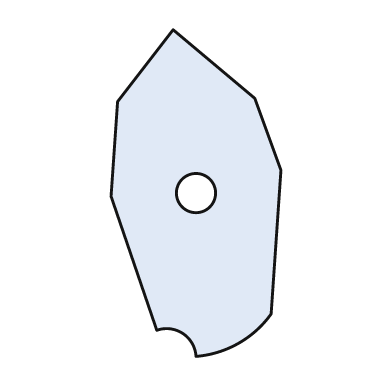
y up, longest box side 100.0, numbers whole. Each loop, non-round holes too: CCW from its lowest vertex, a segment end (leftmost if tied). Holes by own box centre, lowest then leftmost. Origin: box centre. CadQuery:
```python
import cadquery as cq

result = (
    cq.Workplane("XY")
    .moveTo(0.0, -50.0)
    .threePointArc((13.0, -46.0), (23.0, -37.0))
    .lineTo(26.0, 7.0)
    .lineTo(18.0, 29.0)
    .lineTo(-7.0, 50.0)
    .lineTo(-24.0, 28.0)
    .lineTo(-26.0, -1.0)
    .lineTo(-12.0, -42.0)
    .threePointArc((-4.0, -43.0), (0.0, -50.0))
    .close()
    .moveTo(0.0, 0.0)
    .circle(6.0)
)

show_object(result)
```